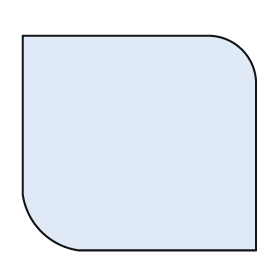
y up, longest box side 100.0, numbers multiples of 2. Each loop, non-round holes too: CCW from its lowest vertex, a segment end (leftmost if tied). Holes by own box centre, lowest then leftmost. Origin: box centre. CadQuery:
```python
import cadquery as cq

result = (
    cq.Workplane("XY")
    .moveTo(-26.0, -46.0)
    .lineTo(50.0, -46.0)
    .lineTo(50.0, 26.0)
    .threePointArc((44.0, 40.0), (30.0, 46.0))
    .lineTo(-50.0, 46.0)
    .lineTo(-50.0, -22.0)
    .threePointArc((-42.0, -38.0), (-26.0, -46.0))
    .close()
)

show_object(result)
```